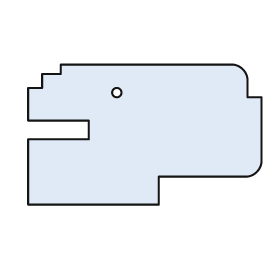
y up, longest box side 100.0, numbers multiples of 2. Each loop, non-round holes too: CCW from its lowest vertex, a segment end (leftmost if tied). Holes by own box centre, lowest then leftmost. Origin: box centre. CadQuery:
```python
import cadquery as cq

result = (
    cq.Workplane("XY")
    .moveTo(-50.0, -30.0)
    .lineTo(6.0, -30.0)
    .lineTo(6.0, -18.0)
    .lineTo(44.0, -18.0)
    .threePointArc((48.0, -16.0), (50.0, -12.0))
    .lineTo(50.0, 16.0)
    .lineTo(44.0, 16.0)
    .lineTo(44.0, 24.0)
    .threePointArc((42.0, 28.0), (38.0, 30.0))
    .lineTo(-36.0, 30.0)
    .lineTo(-36.0, 26.0)
    .lineTo(-44.0, 26.0)
    .lineTo(-44.0, 20.0)
    .lineTo(-50.0, 20.0)
    .lineTo(-50.0, 6.0)
    .lineTo(-24.0, 6.0)
    .lineTo(-24.0, -2.0)
    .lineTo(-50.0, -2.0)
    .close()
    .moveTo(-12.0, 18.0)
    .circle(2.0)
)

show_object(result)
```